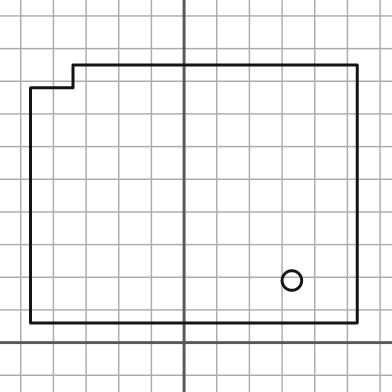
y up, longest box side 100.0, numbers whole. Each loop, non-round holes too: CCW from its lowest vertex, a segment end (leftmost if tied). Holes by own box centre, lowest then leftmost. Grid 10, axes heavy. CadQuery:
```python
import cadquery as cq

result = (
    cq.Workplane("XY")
    .moveTo(-47.0, 6.0)
    .lineTo(53.0, 6.0)
    .lineTo(53.0, 85.0)
    .lineTo(-34.0, 85.0)
    .lineTo(-34.0, 78.0)
    .lineTo(-47.0, 78.0)
    .close()
    .moveTo(33.0, 19.0)
    .circle(3.0)
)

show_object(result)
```